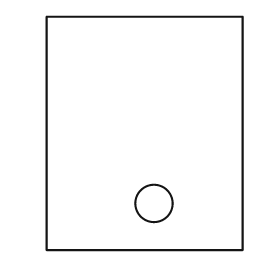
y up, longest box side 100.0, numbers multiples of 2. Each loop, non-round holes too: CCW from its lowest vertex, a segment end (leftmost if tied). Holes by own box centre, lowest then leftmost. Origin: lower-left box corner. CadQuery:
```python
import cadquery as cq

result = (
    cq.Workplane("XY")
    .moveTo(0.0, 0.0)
    .lineTo(84.0, 0.0)
    .lineTo(84.0, 100.0)
    .lineTo(0.0, 100.0)
    .close()
    .moveTo(46.0, 20.0)
    .circle(8.0)
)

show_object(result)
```